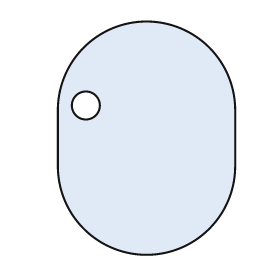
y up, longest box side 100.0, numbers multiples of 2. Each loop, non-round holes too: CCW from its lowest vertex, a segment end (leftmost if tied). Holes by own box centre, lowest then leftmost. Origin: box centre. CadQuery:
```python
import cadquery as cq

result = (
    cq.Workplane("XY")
    .moveTo(-38.0, -12.0)
    .threePointArc((0.0, -50.0), (38.0, -12.0))
    .lineTo(38.0, 12.0)
    .threePointArc((0.0, 50.0), (-38.0, 12.0))
    .close()
    .moveTo(-26.0, 14.0)
    .circle(6.0)
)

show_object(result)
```